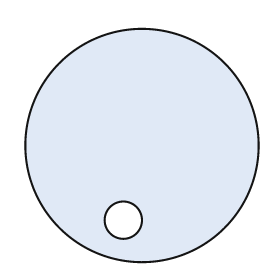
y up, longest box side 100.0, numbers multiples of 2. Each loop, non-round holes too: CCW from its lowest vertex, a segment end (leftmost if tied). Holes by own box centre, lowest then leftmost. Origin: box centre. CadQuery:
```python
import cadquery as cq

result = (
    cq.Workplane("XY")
    .moveTo(0.0, 0.0)
    .circle(50.0)
    .moveTo(-8.0, -32.0)
    .circle(8.0)
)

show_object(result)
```